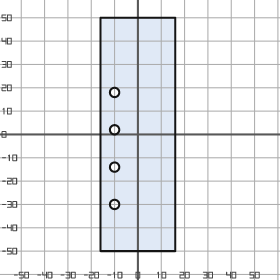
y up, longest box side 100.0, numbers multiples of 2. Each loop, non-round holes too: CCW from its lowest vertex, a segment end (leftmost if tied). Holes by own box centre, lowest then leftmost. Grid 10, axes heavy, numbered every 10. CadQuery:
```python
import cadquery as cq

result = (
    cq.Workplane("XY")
    .moveTo(-16.0, -50.0)
    .lineTo(16.0, -50.0)
    .lineTo(16.0, 50.0)
    .lineTo(-16.0, 50.0)
    .close()
    .moveTo(-10.0, -30.0)
    .circle(2.0)
    .moveTo(-10.0, -14.0)
    .circle(2.0)
    .moveTo(-10.0, 2.0)
    .circle(2.0)
    .moveTo(-10.0, 18.0)
    .circle(2.0)
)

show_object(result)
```